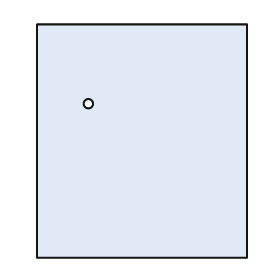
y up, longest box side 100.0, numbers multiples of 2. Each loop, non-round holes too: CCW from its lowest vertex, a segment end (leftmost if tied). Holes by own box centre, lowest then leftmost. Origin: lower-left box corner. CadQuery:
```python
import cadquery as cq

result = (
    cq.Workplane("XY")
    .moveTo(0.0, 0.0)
    .lineTo(90.0, 0.0)
    .lineTo(90.0, 100.0)
    .lineTo(0.0, 100.0)
    .close()
    .moveTo(22.0, 66.0)
    .circle(2.0)
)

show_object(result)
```